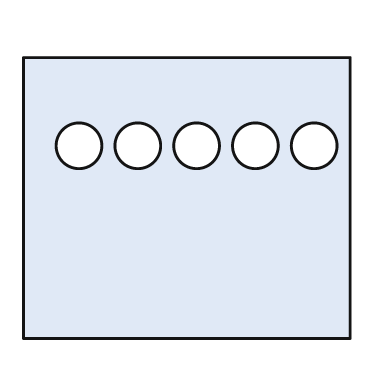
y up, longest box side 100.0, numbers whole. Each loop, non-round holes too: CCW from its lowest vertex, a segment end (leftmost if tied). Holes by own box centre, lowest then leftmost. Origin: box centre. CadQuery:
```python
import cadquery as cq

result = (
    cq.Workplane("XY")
    .moveTo(-50.0, -43.0)
    .lineTo(50.0, -43.0)
    .lineTo(50.0, 43.0)
    .lineTo(-50.0, 43.0)
    .close()
    .moveTo(-33.0, 16.0)
    .circle(7.0)
    .moveTo(-15.0, 16.0)
    .circle(7.0)
    .moveTo(3.0, 16.0)
    .circle(7.0)
    .moveTo(21.0, 16.0)
    .circle(7.0)
    .moveTo(39.0, 16.0)
    .circle(7.0)
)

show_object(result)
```